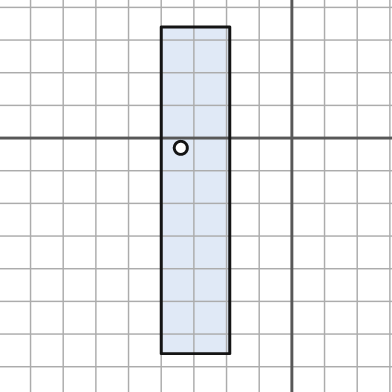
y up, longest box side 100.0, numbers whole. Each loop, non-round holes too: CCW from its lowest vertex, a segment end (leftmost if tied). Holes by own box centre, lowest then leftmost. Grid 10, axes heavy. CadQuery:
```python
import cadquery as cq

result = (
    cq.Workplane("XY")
    .moveTo(-40.0, -66.0)
    .lineTo(-19.0, -66.0)
    .lineTo(-19.0, 34.0)
    .lineTo(-40.0, 34.0)
    .close()
    .moveTo(-34.0, -3.0)
    .circle(2.0)
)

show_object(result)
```